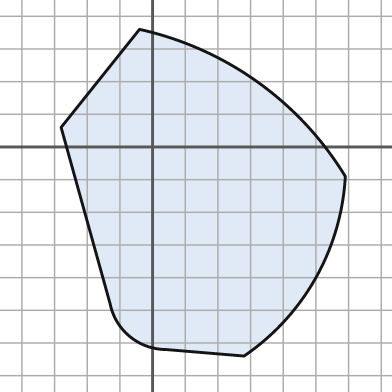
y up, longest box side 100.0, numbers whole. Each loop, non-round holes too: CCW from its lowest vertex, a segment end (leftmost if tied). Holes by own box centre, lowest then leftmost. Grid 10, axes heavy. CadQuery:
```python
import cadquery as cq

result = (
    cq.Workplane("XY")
    .moveTo(28.0, -64.0)
    .threePointArc((50.0, -40.0), (59.0, -9.0))
    .threePointArc((32.0, 20.0), (-4.0, 36.0))
    .lineTo(-28.0, 6.0)
    .lineTo(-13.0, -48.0)
    .threePointArc((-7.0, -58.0), (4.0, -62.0))
    .close()
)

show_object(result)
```